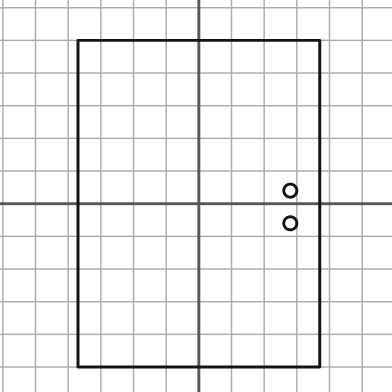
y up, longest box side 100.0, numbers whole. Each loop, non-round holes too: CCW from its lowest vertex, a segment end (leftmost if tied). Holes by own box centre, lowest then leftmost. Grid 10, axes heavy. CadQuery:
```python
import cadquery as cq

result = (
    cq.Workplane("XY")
    .moveTo(-37.0, -50.0)
    .lineTo(37.0, -50.0)
    .lineTo(37.0, 50.0)
    .lineTo(-37.0, 50.0)
    .close()
    .moveTo(28.0, -6.0)
    .circle(2.0)
    .moveTo(28.0, 4.0)
    .circle(2.0)
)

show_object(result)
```